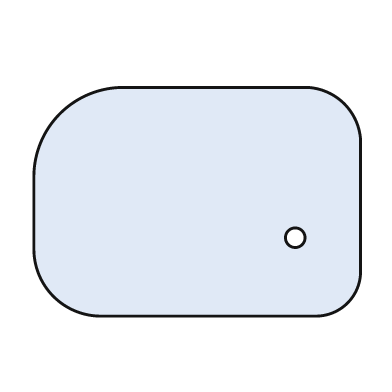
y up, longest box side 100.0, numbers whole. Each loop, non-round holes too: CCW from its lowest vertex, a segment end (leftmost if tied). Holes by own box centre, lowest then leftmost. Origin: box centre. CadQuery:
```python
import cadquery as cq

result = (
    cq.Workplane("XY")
    .moveTo(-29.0, -35.0)
    .lineTo(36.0, -35.0)
    .threePointArc((46.0, -31.0), (50.0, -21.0))
    .lineTo(50.0, 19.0)
    .threePointArc((45.0, 30.0), (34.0, 35.0))
    .lineTo(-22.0, 35.0)
    .threePointArc((-42.0, 27.0), (-50.0, 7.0))
    .lineTo(-50.0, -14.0)
    .threePointArc((-44.0, -29.0), (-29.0, -35.0))
    .close()
    .moveTo(30.0, -11.0)
    .circle(3.0)
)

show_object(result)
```